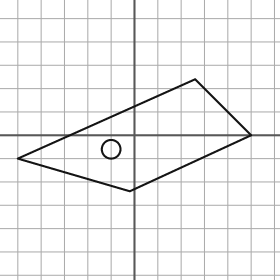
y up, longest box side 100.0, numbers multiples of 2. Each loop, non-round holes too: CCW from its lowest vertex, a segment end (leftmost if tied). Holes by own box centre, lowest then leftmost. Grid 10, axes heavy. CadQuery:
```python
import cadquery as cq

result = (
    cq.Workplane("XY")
    .moveTo(-2.0, -24.0)
    .lineTo(50.0, 0.0)
    .lineTo(26.0, 24.0)
    .lineTo(-50.0, -10.0)
    .close()
    .moveTo(-10.0, -6.0)
    .circle(4.0)
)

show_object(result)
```